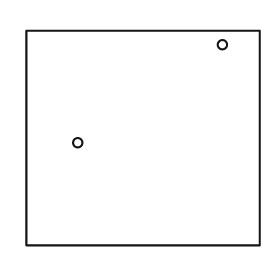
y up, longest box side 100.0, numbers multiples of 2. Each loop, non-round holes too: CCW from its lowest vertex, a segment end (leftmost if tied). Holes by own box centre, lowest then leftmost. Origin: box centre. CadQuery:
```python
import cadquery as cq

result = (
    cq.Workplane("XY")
    .moveTo(-50.0, -46.0)
    .lineTo(50.0, -46.0)
    .lineTo(50.0, 46.0)
    .lineTo(-50.0, 46.0)
    .close()
    .moveTo(-28.0, -2.0)
    .circle(2.0)
    .moveTo(34.0, 40.0)
    .circle(2.0)
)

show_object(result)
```